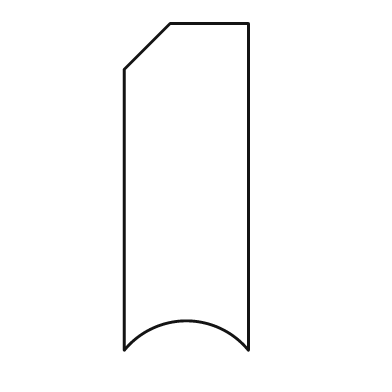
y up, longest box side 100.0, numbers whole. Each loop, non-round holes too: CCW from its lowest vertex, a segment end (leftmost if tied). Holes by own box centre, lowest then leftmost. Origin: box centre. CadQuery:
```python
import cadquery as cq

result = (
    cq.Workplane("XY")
    .moveTo(-19.0, -50.0)
    .threePointArc((0.0, -41.0), (19.0, -50.0))
    .lineTo(19.0, 50.0)
    .lineTo(-5.0, 50.0)
    .lineTo(-19.0, 36.0)
    .close()
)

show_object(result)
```